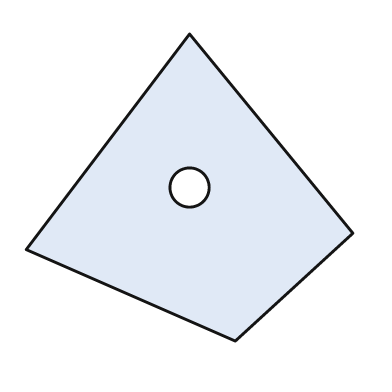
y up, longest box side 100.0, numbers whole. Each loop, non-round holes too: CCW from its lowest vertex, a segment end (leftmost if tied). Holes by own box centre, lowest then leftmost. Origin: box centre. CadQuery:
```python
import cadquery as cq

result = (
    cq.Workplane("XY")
    .moveTo(14.0, -47.0)
    .lineTo(50.0, -14.0)
    .lineTo(0.0, 47.0)
    .lineTo(-50.0, -19.0)
    .close()
    .moveTo(0.0, 0.0)
    .circle(6.0)
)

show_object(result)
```